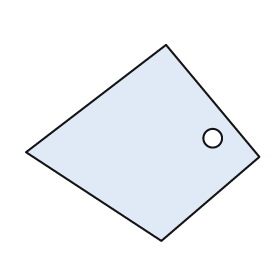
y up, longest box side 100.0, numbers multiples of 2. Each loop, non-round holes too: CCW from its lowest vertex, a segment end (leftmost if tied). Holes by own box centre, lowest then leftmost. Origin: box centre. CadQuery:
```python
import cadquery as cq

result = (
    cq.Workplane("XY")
    .moveTo(8.0, -42.0)
    .lineTo(50.0, -6.0)
    .lineTo(10.0, 42.0)
    .lineTo(-50.0, -4.0)
    .close()
    .moveTo(30.0, 2.0)
    .circle(4.0)
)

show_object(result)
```